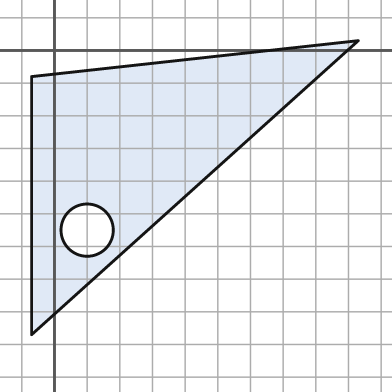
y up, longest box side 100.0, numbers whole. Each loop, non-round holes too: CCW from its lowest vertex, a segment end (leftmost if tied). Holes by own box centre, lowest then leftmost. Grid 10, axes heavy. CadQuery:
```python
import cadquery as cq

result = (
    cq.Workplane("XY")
    .moveTo(-7.0, -87.0)
    .lineTo(93.0, 3.0)
    .lineTo(-7.0, -8.0)
    .close()
    .moveTo(10.0, -55.0)
    .circle(8.0)
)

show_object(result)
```